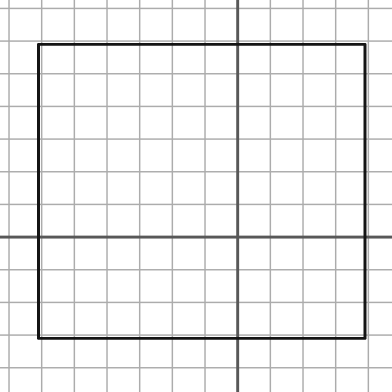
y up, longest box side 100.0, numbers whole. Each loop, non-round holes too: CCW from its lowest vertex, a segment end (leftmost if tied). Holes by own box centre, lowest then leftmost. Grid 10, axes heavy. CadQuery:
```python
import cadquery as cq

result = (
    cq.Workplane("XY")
    .moveTo(-61.0, -31.0)
    .lineTo(39.0, -31.0)
    .lineTo(39.0, 59.0)
    .lineTo(-61.0, 59.0)
    .close()
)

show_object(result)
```